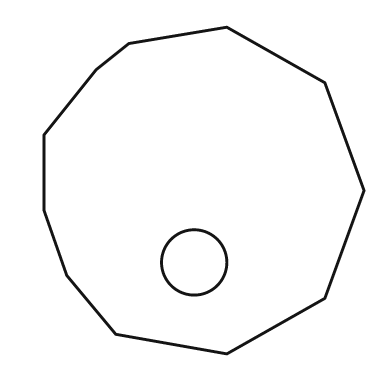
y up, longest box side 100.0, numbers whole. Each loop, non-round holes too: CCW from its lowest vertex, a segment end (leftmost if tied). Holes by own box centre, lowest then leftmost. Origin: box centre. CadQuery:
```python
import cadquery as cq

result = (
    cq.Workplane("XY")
    .moveTo(7.0, -50.0)
    .lineTo(37.0, -33.0)
    .lineTo(49.0, 0.0)
    .lineTo(37.0, 33.0)
    .lineTo(7.0, 50.0)
    .lineTo(-23.0, 45.0)
    .lineTo(-33.0, 37.0)
    .lineTo(-49.0, 17.0)
    .lineTo(-49.0, -6.0)
    .lineTo(-42.0, -26.0)
    .lineTo(-27.0, -44.0)
    .close()
    .moveTo(-3.0, -22.0)
    .circle(10.0)
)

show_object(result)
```